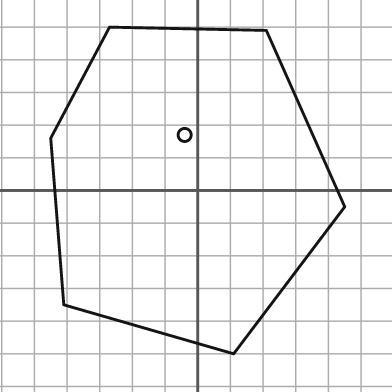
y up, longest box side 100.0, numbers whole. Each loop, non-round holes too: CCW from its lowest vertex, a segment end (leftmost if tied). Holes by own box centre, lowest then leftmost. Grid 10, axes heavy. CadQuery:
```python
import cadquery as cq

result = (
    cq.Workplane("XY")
    .moveTo(11.0, -50.0)
    .lineTo(45.0, -5.0)
    .lineTo(21.0, 49.0)
    .lineTo(-27.0, 50.0)
    .lineTo(-45.0, 16.0)
    .lineTo(-41.0, -35.0)
    .close()
    .moveTo(-4.0, 17.0)
    .circle(2.0)
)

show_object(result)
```